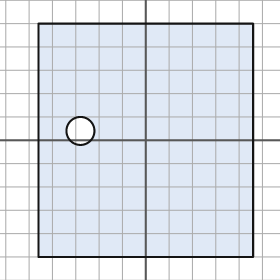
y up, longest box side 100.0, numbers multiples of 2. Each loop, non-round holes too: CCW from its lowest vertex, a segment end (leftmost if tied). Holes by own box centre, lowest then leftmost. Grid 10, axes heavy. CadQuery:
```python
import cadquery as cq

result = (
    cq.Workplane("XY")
    .moveTo(-46.0, -50.0)
    .lineTo(46.0, -50.0)
    .lineTo(46.0, 50.0)
    .lineTo(-46.0, 50.0)
    .close()
    .moveTo(-28.0, 4.0)
    .circle(6.0)
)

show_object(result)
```